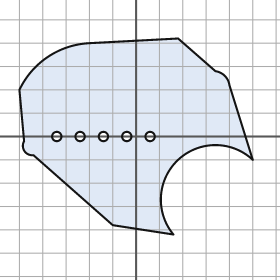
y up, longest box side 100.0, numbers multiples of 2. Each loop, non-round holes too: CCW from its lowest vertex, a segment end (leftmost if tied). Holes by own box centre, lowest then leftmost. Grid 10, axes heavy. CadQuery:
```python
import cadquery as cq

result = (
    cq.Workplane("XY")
    .moveTo(16.0, -42.0)
    .threePointArc((18.0, -10.0), (50.0, -10.0))
    .lineTo(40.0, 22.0)
    .threePointArc((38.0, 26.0), (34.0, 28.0))
    .lineTo(18.0, 42.0)
    .lineTo(-20.0, 40.0)
    .threePointArc((-38.0, 34.0), (-50.0, 20.0))
    .lineTo(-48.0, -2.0)
    .threePointArc((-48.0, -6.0), (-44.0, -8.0))
    .lineTo(-10.0, -38.0)
    .close()
    .moveTo(-34.0, 0.0)
    .circle(2.0)
    .moveTo(-24.0, 0.0)
    .circle(2.0)
    .moveTo(-14.0, 0.0)
    .circle(2.0)
    .moveTo(-4.0, 0.0)
    .circle(2.0)
    .moveTo(6.0, 0.0)
    .circle(2.0)
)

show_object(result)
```